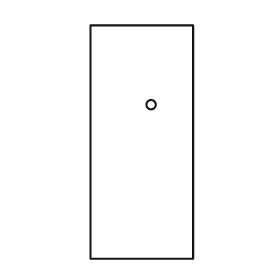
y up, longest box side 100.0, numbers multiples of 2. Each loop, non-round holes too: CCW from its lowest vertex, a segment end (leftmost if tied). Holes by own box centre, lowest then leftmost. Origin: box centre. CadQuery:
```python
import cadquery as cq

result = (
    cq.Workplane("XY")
    .moveTo(-22.0, -50.0)
    .lineTo(22.0, -50.0)
    .lineTo(22.0, 50.0)
    .lineTo(-22.0, 50.0)
    .close()
    .moveTo(4.0, 16.0)
    .circle(2.0)
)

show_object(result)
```